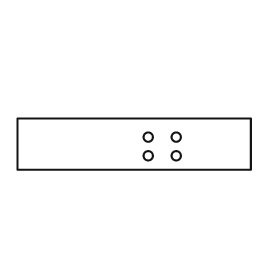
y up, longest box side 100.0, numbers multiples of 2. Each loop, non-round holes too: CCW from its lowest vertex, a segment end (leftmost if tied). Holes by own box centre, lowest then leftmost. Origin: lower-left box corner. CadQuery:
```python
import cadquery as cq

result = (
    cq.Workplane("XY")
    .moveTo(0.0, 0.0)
    .lineTo(100.0, 0.0)
    .lineTo(100.0, 22.0)
    .lineTo(0.0, 22.0)
    .close()
    .moveTo(56.0, 6.0)
    .circle(2.0)
    .moveTo(68.0, 6.0)
    .circle(2.0)
    .moveTo(56.0, 14.0)
    .circle(2.0)
    .moveTo(68.0, 14.0)
    .circle(2.0)
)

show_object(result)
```